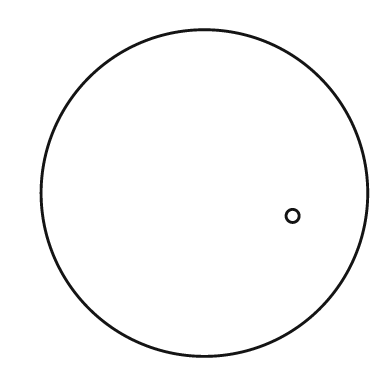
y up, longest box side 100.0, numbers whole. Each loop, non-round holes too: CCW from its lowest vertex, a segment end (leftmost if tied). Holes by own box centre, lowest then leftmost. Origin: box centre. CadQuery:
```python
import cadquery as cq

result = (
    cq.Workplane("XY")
    .moveTo(0.0, 0.0)
    .circle(50.0)
    .moveTo(27.0, -7.0)
    .circle(2.0)
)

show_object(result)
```